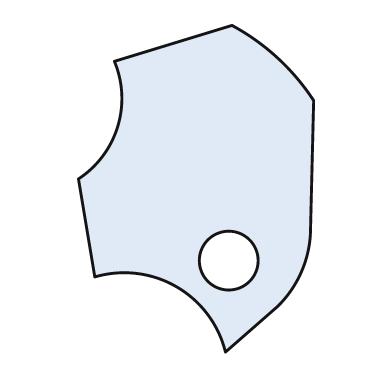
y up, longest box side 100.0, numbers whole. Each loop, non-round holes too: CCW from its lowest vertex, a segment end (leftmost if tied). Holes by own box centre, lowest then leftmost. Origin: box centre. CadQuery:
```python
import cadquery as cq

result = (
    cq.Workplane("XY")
    .moveTo(9.0, -50.0)
    .lineTo(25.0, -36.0)
    .threePointArc((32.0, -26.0), (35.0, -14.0))
    .lineTo(36.0, 27.0)
    .threePointArc((25.0, 40.0), (11.0, 50.0))
    .lineTo(-25.0, 39.0)
    .threePointArc((-24.0, 19.0), (-36.0, 3.0))
    .lineTo(-31.0, -27.0)
    .threePointArc((-6.0, -30.0), (9.0, -50.0))
    .close()
    .moveTo(10.0, -22.0)
    .circle(9.0)
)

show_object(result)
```